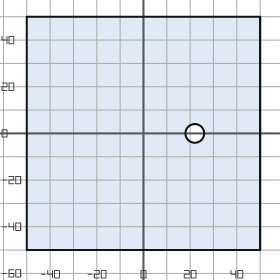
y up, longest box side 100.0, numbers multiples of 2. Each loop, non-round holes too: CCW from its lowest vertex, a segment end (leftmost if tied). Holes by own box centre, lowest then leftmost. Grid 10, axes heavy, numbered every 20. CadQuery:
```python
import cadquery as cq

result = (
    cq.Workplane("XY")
    .moveTo(-50.0, -50.0)
    .lineTo(50.0, -50.0)
    .lineTo(50.0, 50.0)
    .lineTo(-50.0, 50.0)
    .close()
    .moveTo(22.0, 0.0)
    .circle(4.0)
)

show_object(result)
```